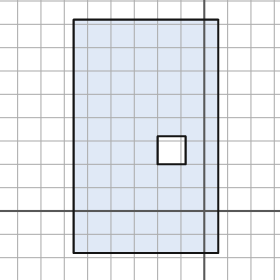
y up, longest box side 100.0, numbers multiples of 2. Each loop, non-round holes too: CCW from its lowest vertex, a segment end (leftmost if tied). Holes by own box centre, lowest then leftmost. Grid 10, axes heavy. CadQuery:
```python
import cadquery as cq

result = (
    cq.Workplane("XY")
    .moveTo(-56.0, -18.0)
    .lineTo(6.0, -18.0)
    .lineTo(6.0, 82.0)
    .lineTo(-56.0, 82.0)
    .close()
    .moveTo(-20.0, 20.0)
    .lineTo(-8.0, 20.0)
    .lineTo(-8.0, 32.0)
    .lineTo(-20.0, 32.0)
    .close()
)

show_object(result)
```